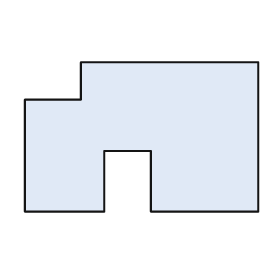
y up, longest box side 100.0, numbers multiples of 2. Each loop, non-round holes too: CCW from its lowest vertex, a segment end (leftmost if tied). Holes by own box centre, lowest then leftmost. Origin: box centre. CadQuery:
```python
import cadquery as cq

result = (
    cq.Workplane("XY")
    .moveTo(-50.0, -32.0)
    .lineTo(-16.0, -32.0)
    .lineTo(-16.0, -6.0)
    .lineTo(4.0, -6.0)
    .lineTo(4.0, -32.0)
    .lineTo(50.0, -32.0)
    .lineTo(50.0, 32.0)
    .lineTo(-26.0, 32.0)
    .lineTo(-26.0, 16.0)
    .lineTo(-50.0, 16.0)
    .close()
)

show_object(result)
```